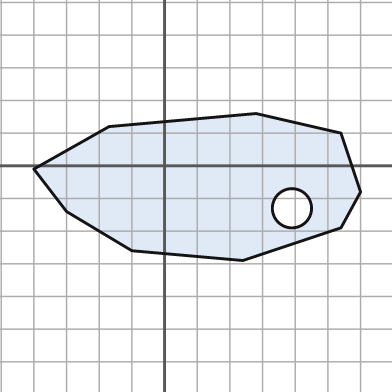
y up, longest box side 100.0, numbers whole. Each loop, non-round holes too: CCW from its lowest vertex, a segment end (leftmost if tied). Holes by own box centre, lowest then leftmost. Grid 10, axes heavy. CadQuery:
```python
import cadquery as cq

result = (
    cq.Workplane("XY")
    .moveTo(24.0, -29.0)
    .lineTo(54.0, -19.0)
    .lineTo(60.0, -8.0)
    .lineTo(54.0, 10.0)
    .lineTo(28.0, 16.0)
    .lineTo(-17.0, 12.0)
    .lineTo(-40.0, -1.0)
    .lineTo(-30.0, -14.0)
    .lineTo(-10.0, -26.0)
    .close()
    .moveTo(39.0, -13.0)
    .circle(6.0)
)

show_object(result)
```